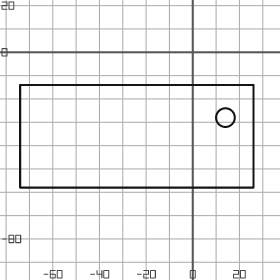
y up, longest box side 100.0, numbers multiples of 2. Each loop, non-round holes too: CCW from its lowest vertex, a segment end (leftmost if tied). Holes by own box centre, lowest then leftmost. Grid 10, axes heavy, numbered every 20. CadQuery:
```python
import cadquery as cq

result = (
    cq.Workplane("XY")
    .moveTo(-74.0, -58.0)
    .lineTo(26.0, -58.0)
    .lineTo(26.0, -14.0)
    .lineTo(-74.0, -14.0)
    .close()
    .moveTo(14.0, -28.0)
    .circle(4.0)
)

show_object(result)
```